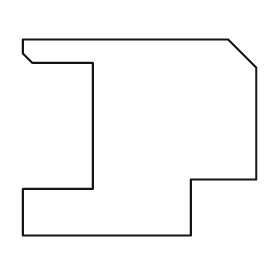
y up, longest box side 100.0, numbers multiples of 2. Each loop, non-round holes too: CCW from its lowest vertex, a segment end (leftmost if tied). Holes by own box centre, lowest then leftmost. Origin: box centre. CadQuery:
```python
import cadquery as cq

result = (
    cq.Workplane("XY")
    .moveTo(-50.0, -42.0)
    .lineTo(22.0, -42.0)
    .lineTo(22.0, -18.0)
    .lineTo(50.0, -18.0)
    .lineTo(50.0, 30.0)
    .lineTo(38.0, 42.0)
    .lineTo(-50.0, 42.0)
    .lineTo(-50.0, 36.0)
    .lineTo(-46.0, 32.0)
    .lineTo(-20.0, 32.0)
    .lineTo(-20.0, -22.0)
    .lineTo(-50.0, -22.0)
    .close()
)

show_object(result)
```